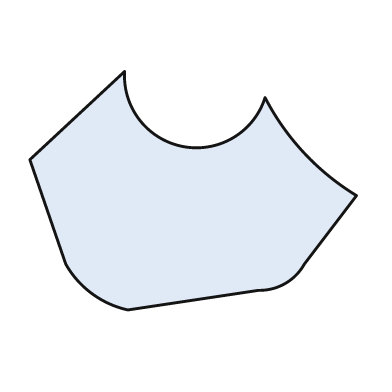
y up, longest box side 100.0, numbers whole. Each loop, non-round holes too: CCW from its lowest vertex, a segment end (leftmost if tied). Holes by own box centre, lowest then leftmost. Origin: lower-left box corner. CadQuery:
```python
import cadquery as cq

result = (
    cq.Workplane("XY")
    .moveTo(30.0, 0.0)
    .lineTo(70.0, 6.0)
    .threePointArc((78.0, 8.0), (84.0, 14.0))
    .lineTo(100.0, 35.0)
    .threePointArc((84.0, 48.0), (72.0, 65.0))
    .threePointArc((47.0, 50.0), (29.0, 73.0))
    .lineTo(0.0, 46.0)
    .lineTo(11.0, 14.0)
    .threePointArc((19.0, 5.0), (30.0, 0.0))
    .close()
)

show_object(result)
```